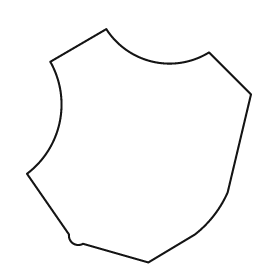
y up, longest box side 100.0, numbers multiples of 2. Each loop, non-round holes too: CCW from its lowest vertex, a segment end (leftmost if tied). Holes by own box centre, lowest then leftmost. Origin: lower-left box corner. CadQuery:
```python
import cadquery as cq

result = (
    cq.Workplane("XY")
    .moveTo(52.0, 0.0)
    .lineTo(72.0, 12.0)
    .threePointArc((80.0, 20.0), (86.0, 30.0))
    .lineTo(96.0, 72.0)
    .lineTo(78.0, 90.0)
    .threePointArc((54.0, 86.0), (34.0, 100.0))
    .lineTo(10.0, 86.0)
    .threePointArc((14.0, 60.0), (0.0, 38.0))
    .lineTo(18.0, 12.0)
    .threePointArc((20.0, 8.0), (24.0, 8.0))
    .close()
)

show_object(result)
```